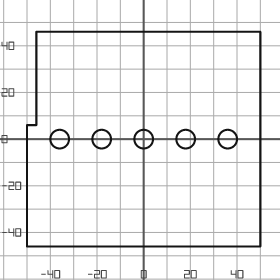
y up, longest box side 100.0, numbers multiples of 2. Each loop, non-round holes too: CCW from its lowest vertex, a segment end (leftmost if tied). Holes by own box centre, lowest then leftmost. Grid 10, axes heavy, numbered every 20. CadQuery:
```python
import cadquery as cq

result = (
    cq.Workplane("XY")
    .moveTo(-50.0, -46.0)
    .lineTo(50.0, -46.0)
    .lineTo(50.0, 46.0)
    .lineTo(-46.0, 46.0)
    .lineTo(-46.0, 6.0)
    .lineTo(-50.0, 6.0)
    .close()
    .moveTo(-36.0, 0.0)
    .circle(4.0)
    .moveTo(-18.0, 0.0)
    .circle(4.0)
    .moveTo(0.0, 0.0)
    .circle(4.0)
    .moveTo(18.0, 0.0)
    .circle(4.0)
    .moveTo(36.0, 0.0)
    .circle(4.0)
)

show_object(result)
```